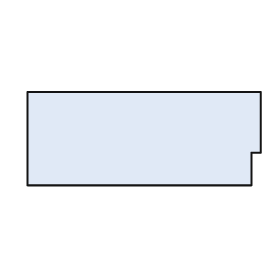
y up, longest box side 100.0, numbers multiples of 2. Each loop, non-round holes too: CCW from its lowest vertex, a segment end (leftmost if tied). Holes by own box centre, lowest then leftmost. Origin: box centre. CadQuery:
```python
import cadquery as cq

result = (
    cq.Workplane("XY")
    .moveTo(-50.0, -20.0)
    .lineTo(46.0, -20.0)
    .lineTo(46.0, -6.0)
    .lineTo(50.0, -6.0)
    .lineTo(50.0, 20.0)
    .lineTo(-50.0, 20.0)
    .close()
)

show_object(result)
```